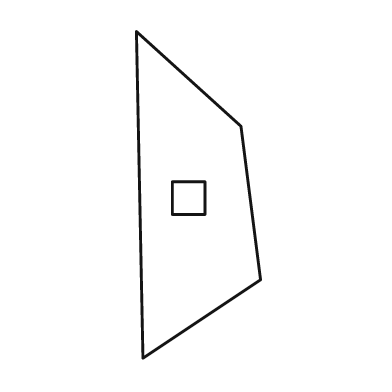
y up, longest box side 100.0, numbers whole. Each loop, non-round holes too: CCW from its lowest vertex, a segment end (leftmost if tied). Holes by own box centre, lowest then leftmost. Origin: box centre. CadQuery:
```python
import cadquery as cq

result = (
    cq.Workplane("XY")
    .moveTo(-17.0, -50.0)
    .lineTo(19.0, -26.0)
    .lineTo(13.0, 21.0)
    .lineTo(-19.0, 50.0)
    .close()
    .moveTo(-8.0, -6.0)
    .lineTo(2.0, -6.0)
    .lineTo(2.0, 4.0)
    .lineTo(-8.0, 4.0)
    .close()
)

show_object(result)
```